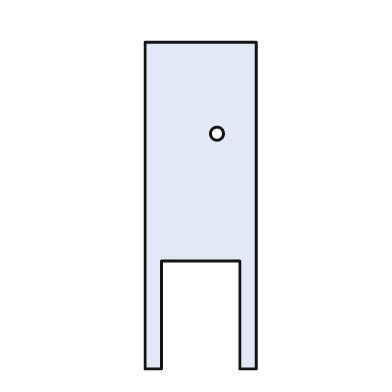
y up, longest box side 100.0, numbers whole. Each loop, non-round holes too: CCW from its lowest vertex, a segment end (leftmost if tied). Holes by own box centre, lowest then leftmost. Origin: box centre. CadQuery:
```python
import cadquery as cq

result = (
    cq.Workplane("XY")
    .moveTo(-17.0, -50.0)
    .lineTo(-12.0, -50.0)
    .lineTo(-12.0, -17.0)
    .lineTo(12.0, -17.0)
    .lineTo(12.0, -50.0)
    .lineTo(17.0, -50.0)
    .lineTo(17.0, 50.0)
    .lineTo(-17.0, 50.0)
    .close()
    .moveTo(5.0, 22.0)
    .circle(2.0)
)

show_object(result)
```